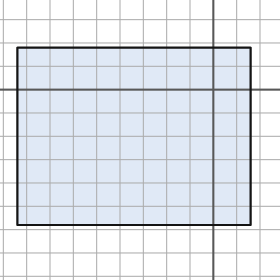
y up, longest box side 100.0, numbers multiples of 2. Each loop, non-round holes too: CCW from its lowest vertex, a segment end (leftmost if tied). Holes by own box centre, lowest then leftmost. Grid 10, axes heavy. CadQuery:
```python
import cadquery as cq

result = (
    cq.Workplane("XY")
    .moveTo(-84.0, -58.0)
    .lineTo(16.0, -58.0)
    .lineTo(16.0, 18.0)
    .lineTo(-84.0, 18.0)
    .close()
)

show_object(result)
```